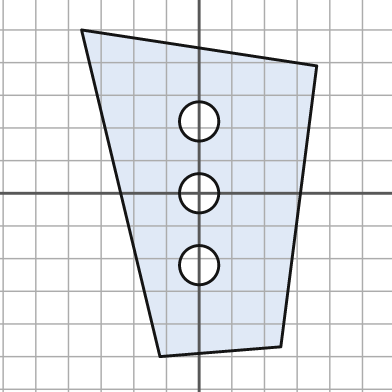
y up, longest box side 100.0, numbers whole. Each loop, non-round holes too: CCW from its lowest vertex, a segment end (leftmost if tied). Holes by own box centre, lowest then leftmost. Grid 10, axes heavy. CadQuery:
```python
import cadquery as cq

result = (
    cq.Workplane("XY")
    .moveTo(-12.0, -50.0)
    .lineTo(25.0, -47.0)
    .lineTo(36.0, 39.0)
    .lineTo(-36.0, 50.0)
    .close()
    .moveTo(0.0, -22.0)
    .circle(6.0)
    .moveTo(0.0, 0.0)
    .circle(6.0)
    .moveTo(0.0, 22.0)
    .circle(6.0)
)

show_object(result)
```